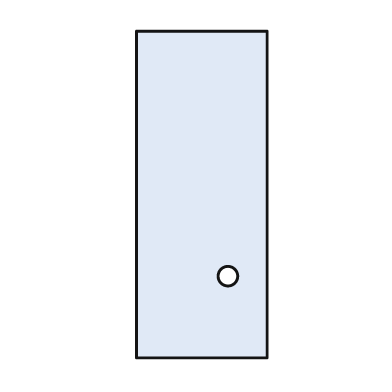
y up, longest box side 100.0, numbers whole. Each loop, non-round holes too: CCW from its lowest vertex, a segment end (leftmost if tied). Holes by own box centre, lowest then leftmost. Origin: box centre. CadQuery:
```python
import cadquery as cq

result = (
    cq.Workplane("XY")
    .moveTo(-20.0, -50.0)
    .lineTo(20.0, -50.0)
    .lineTo(20.0, 50.0)
    .lineTo(-20.0, 50.0)
    .close()
    .moveTo(8.0, -25.0)
    .circle(3.0)
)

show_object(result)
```